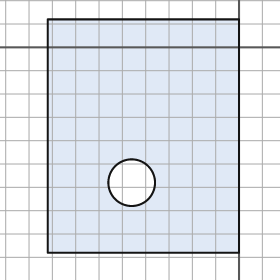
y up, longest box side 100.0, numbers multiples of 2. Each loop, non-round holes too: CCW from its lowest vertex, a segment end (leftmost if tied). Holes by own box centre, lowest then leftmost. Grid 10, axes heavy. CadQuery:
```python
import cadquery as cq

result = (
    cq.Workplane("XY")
    .moveTo(-82.0, -88.0)
    .lineTo(0.0, -88.0)
    .lineTo(0.0, 12.0)
    .lineTo(-82.0, 12.0)
    .close()
    .moveTo(-46.0, -58.0)
    .circle(10.0)
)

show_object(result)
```